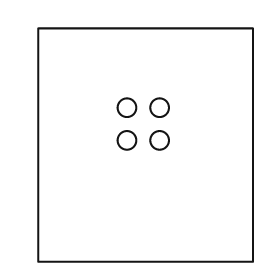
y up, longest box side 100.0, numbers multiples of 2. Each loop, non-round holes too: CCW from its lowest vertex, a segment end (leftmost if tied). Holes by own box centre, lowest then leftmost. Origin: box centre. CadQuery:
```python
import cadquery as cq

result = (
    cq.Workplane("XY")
    .moveTo(-46.0, -50.0)
    .lineTo(46.0, -50.0)
    .lineTo(46.0, 50.0)
    .lineTo(-46.0, 50.0)
    .close()
    .moveTo(-8.0, 2.0)
    .circle(4.0)
    .moveTo(6.0, 2.0)
    .circle(4.0)
    .moveTo(-8.0, 16.0)
    .circle(4.0)
    .moveTo(6.0, 16.0)
    .circle(4.0)
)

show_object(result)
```